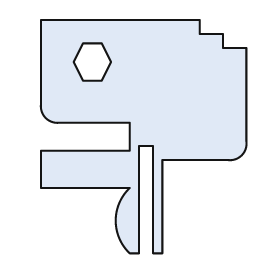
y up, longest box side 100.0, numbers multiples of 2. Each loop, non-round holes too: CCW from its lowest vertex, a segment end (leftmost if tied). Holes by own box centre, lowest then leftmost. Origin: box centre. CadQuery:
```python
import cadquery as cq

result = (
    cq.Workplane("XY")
    .moveTo(-6.0, -50.0)
    .lineTo(-2.0, -50.0)
    .lineTo(-2.0, -4.0)
    .lineTo(4.0, -4.0)
    .lineTo(4.0, -50.0)
    .lineTo(8.0, -50.0)
    .lineTo(8.0, -10.0)
    .lineTo(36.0, -10.0)
    .threePointArc((42.0, -8.0), (44.0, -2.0))
    .lineTo(44.0, 38.0)
    .lineTo(34.0, 38.0)
    .lineTo(34.0, 44.0)
    .lineTo(24.0, 44.0)
    .lineTo(24.0, 50.0)
    .lineTo(-44.0, 50.0)
    .lineTo(-44.0, 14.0)
    .threePointArc((-42.0, 8.0), (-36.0, 6.0))
    .lineTo(-6.0, 6.0)
    .lineTo(-6.0, -6.0)
    .lineTo(-44.0, -6.0)
    .lineTo(-44.0, -22.0)
    .lineTo(-6.0, -22.0)
    .threePointArc((-12.0, -36.0), (-6.0, -50.0))
    .close()
    .moveTo(-26.0, 24.0)
    .lineTo(-18.0, 24.0)
    .lineTo(-14.0, 32.0)
    .lineTo(-18.0, 40.0)
    .lineTo(-26.0, 40.0)
    .lineTo(-30.0, 32.0)
    .close()
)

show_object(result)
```